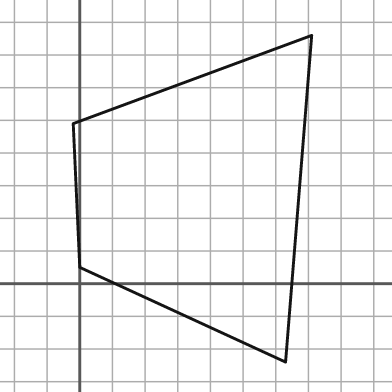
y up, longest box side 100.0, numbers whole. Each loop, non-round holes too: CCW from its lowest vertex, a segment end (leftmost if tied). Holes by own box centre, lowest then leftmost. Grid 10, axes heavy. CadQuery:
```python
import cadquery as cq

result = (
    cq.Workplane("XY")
    .moveTo(63.0, -24.0)
    .lineTo(71.0, 76.0)
    .lineTo(-2.0, 49.0)
    .lineTo(0.0, 5.0)
    .close()
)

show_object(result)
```